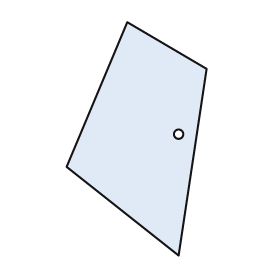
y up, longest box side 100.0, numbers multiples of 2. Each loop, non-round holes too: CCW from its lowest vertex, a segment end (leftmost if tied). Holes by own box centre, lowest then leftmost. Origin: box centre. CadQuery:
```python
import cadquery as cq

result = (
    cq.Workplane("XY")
    .moveTo(18.0, -50.0)
    .lineTo(30.0, 30.0)
    .lineTo(-4.0, 50.0)
    .lineTo(-30.0, -12.0)
    .close()
    .moveTo(18.0, 2.0)
    .circle(2.0)
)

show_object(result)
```